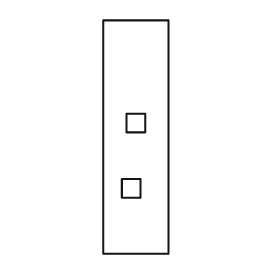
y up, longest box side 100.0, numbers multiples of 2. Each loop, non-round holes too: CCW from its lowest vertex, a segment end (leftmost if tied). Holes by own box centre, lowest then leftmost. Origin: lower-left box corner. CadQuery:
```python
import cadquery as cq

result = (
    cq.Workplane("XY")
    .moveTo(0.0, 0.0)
    .lineTo(28.0, 0.0)
    .lineTo(28.0, 100.0)
    .lineTo(0.0, 100.0)
    .close()
    .moveTo(8.0, 24.0)
    .lineTo(16.0, 24.0)
    .lineTo(16.0, 32.0)
    .lineTo(8.0, 32.0)
    .close()
    .moveTo(10.0, 52.0)
    .lineTo(18.0, 52.0)
    .lineTo(18.0, 60.0)
    .lineTo(10.0, 60.0)
    .close()
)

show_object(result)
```